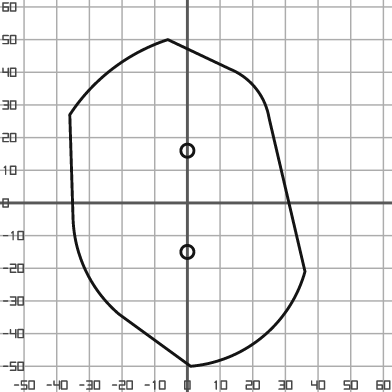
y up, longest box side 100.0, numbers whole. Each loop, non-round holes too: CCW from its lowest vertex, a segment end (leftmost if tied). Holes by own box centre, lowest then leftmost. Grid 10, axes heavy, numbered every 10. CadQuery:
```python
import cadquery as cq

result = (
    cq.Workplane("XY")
    .moveTo(1.0, -50.0)
    .threePointArc((23.0, -41.0), (36.0, -21.0))
    .lineTo(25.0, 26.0)
    .threePointArc((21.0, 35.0), (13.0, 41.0))
    .lineTo(-6.0, 50.0)
    .threePointArc((-23.0, 41.0), (-36.0, 27.0))
    .lineTo(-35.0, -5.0)
    .threePointArc((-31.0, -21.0), (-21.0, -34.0))
    .close()
    .moveTo(0.0, -15.0)
    .circle(2.0)
    .moveTo(0.0, 16.0)
    .circle(2.0)
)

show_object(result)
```